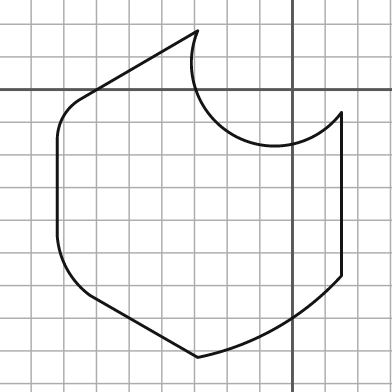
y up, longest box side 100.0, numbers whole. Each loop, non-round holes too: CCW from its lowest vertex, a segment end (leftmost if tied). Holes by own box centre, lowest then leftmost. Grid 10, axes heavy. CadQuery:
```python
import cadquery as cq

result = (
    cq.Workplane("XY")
    .moveTo(-29.0, -82.0)
    .threePointArc((-5.0, -73.0), (15.0, -57.0))
    .lineTo(15.0, -7.0)
    .threePointArc((-18.0, -14.0), (-29.0, 18.0))
    .lineTo(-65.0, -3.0)
    .threePointArc((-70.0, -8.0), (-72.0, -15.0))
    .lineTo(-72.0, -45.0)
    .threePointArc((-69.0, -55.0), (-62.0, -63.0))
    .close()
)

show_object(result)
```